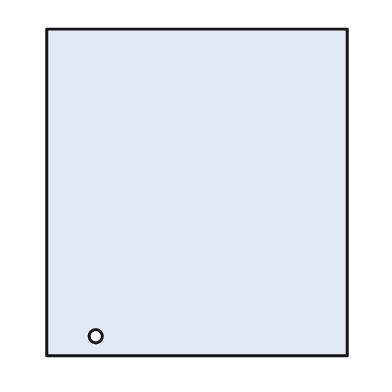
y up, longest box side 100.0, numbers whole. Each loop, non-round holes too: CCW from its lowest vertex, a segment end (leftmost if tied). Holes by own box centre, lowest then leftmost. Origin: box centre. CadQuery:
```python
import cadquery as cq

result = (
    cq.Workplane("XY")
    .moveTo(-46.0, -50.0)
    .lineTo(46.0, -50.0)
    .lineTo(46.0, 50.0)
    .lineTo(-46.0, 50.0)
    .close()
    .moveTo(-31.0, -44.0)
    .circle(2.0)
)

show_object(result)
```